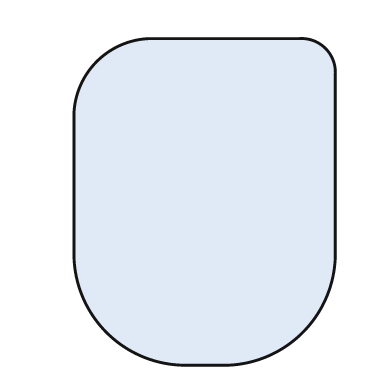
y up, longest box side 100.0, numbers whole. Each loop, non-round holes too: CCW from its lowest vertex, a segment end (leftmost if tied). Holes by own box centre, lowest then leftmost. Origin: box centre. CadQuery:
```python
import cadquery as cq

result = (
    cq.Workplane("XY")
    .moveTo(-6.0, -50.0)
    .lineTo(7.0, -50.0)
    .threePointArc((30.0, -40.0), (40.0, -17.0))
    .lineTo(40.0, 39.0)
    .threePointArc((37.0, 47.0), (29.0, 50.0))
    .lineTo(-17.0, 50.0)
    .threePointArc((-33.0, 43.0), (-40.0, 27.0))
    .lineTo(-40.0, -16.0)
    .threePointArc((-30.0, -40.0), (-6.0, -50.0))
    .close()
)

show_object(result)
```